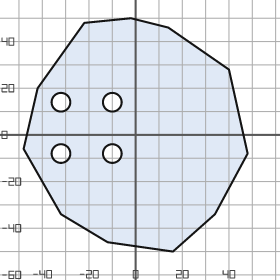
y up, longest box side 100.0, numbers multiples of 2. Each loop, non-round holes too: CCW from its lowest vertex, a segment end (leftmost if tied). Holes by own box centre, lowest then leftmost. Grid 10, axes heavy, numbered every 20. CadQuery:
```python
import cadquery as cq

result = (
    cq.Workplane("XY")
    .moveTo(16.0, -50.0)
    .lineTo(34.0, -34.0)
    .lineTo(48.0, -8.0)
    .lineTo(40.0, 28.0)
    .lineTo(14.0, 46.0)
    .lineTo(-2.0, 50.0)
    .lineTo(-22.0, 48.0)
    .lineTo(-42.0, 20.0)
    .lineTo(-48.0, -6.0)
    .lineTo(-32.0, -34.0)
    .lineTo(-12.0, -46.0)
    .close()
    .moveTo(-32.0, -8.0)
    .circle(4.0)
    .moveTo(-10.0, -8.0)
    .circle(4.0)
    .moveTo(-32.0, 14.0)
    .circle(4.0)
    .moveTo(-10.0, 14.0)
    .circle(4.0)
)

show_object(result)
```